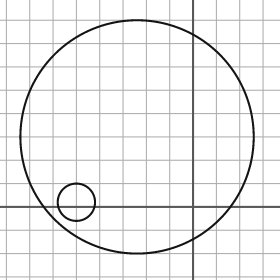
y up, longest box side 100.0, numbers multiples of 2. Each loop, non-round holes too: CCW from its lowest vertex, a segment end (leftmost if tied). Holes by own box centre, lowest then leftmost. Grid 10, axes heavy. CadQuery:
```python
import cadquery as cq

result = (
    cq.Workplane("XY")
    .moveTo(-24.0, 30.0)
    .circle(50.0)
    .moveTo(-50.0, 2.0)
    .circle(8.0)
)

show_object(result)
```